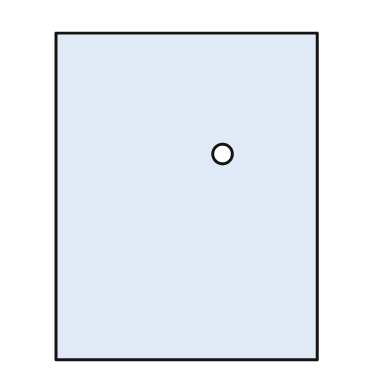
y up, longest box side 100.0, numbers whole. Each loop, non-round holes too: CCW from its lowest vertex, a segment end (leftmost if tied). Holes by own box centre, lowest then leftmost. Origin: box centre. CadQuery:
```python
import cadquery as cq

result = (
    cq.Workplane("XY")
    .moveTo(-40.0, -50.0)
    .lineTo(40.0, -50.0)
    .lineTo(40.0, 50.0)
    .lineTo(-40.0, 50.0)
    .close()
    .moveTo(11.0, 13.0)
    .circle(3.0)
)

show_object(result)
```